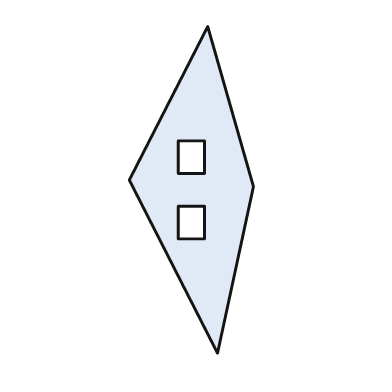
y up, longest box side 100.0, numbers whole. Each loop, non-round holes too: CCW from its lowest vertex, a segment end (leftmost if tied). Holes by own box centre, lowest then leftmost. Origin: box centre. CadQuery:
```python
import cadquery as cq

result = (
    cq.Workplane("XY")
    .moveTo(8.0, -50.0)
    .lineTo(19.0, 1.0)
    .lineTo(5.0, 50.0)
    .lineTo(-19.0, 3.0)
    .close()
    .moveTo(-4.0, -15.0)
    .lineTo(4.0, -15.0)
    .lineTo(4.0, -5.0)
    .lineTo(-4.0, -5.0)
    .close()
    .moveTo(-4.0, 5.0)
    .lineTo(4.0, 5.0)
    .lineTo(4.0, 15.0)
    .lineTo(-4.0, 15.0)
    .close()
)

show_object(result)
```